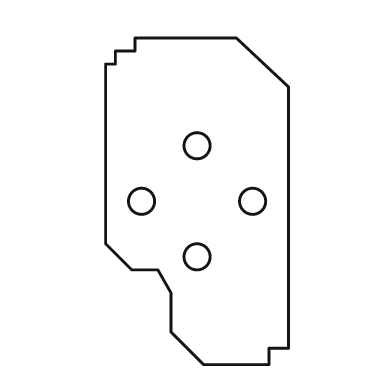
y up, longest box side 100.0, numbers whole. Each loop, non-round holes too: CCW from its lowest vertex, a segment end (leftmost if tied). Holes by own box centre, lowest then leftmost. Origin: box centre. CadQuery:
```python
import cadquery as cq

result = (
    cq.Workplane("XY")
    .moveTo(2.0, -50.0)
    .lineTo(22.0, -50.0)
    .lineTo(22.0, -45.0)
    .lineTo(28.0, -45.0)
    .lineTo(28.0, 35.0)
    .lineTo(12.0, 50.0)
    .lineTo(-19.0, 50.0)
    .lineTo(-19.0, 46.0)
    .lineTo(-25.0, 46.0)
    .lineTo(-25.0, 42.0)
    .lineTo(-28.0, 42.0)
    .lineTo(-28.0, -13.0)
    .lineTo(-20.0, -21.0)
    .lineTo(-12.0, -21.0)
    .lineTo(-8.0, -28.0)
    .lineTo(-8.0, -40.0)
    .close()
    .moveTo(0.0, -17.0)
    .circle(4.0)
    .moveTo(-17.0, 0.0)
    .circle(4.0)
    .moveTo(17.0, 0.0)
    .circle(4.0)
    .moveTo(0.0, 17.0)
    .circle(4.0)
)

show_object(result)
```